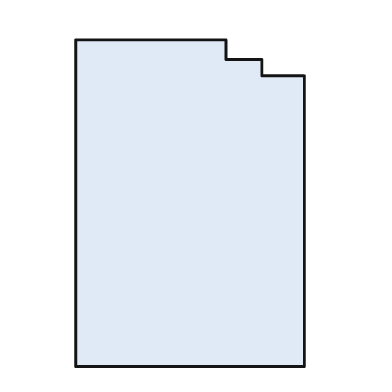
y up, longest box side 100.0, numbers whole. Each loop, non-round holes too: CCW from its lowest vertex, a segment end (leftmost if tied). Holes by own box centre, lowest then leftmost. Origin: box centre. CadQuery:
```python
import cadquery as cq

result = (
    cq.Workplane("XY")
    .moveTo(-35.0, -50.0)
    .lineTo(35.0, -50.0)
    .lineTo(35.0, 39.0)
    .lineTo(22.0, 39.0)
    .lineTo(22.0, 44.0)
    .lineTo(11.0, 44.0)
    .lineTo(11.0, 50.0)
    .lineTo(-35.0, 50.0)
    .close()
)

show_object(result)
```